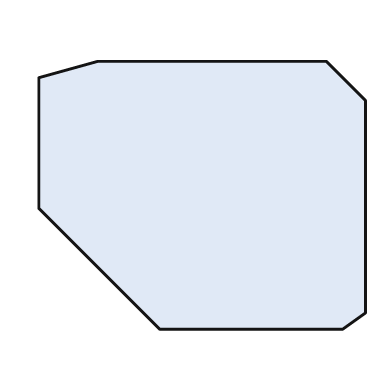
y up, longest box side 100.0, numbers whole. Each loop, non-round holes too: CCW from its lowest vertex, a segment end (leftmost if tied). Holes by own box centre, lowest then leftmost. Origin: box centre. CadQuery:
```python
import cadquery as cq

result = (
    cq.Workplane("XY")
    .moveTo(-13.0, -41.0)
    .lineTo(43.0, -41.0)
    .lineTo(50.0, -36.0)
    .lineTo(50.0, 29.0)
    .lineTo(38.0, 41.0)
    .lineTo(-32.0, 41.0)
    .lineTo(-50.0, 36.0)
    .lineTo(-50.0, -4.0)
    .close()
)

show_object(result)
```